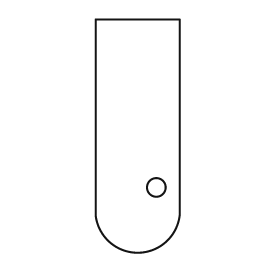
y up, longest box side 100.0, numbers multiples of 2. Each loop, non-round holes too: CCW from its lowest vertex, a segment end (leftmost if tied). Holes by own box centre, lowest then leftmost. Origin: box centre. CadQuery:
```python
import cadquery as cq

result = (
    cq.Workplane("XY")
    .moveTo(-18.0, -34.0)
    .threePointArc((0.0, -50.0), (18.0, -34.0))
    .lineTo(18.0, 50.0)
    .lineTo(-18.0, 50.0)
    .close()
    .moveTo(8.0, -22.0)
    .circle(4.0)
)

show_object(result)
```